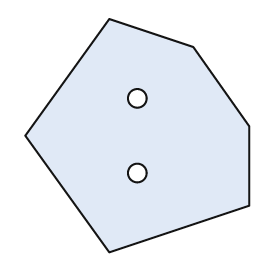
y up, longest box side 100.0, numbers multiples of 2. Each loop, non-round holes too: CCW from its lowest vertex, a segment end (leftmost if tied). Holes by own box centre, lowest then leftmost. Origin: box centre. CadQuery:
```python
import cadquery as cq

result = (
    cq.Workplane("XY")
    .moveTo(-12.0, -50.0)
    .lineTo(48.0, -30.0)
    .lineTo(48.0, 4.0)
    .lineTo(24.0, 38.0)
    .lineTo(-12.0, 50.0)
    .lineTo(-48.0, 0.0)
    .close()
    .moveTo(0.0, -16.0)
    .circle(4.0)
    .moveTo(0.0, 16.0)
    .circle(4.0)
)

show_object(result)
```